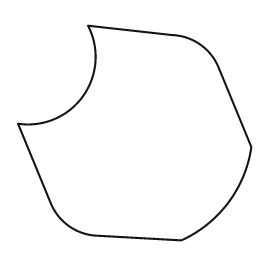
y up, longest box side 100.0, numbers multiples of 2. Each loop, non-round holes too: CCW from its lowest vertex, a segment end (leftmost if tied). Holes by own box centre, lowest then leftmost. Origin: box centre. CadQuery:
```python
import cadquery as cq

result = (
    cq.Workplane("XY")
    .moveTo(20.0, -46.0)
    .threePointArc((40.0, -30.0), (50.0, -6.0))
    .lineTo(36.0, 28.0)
    .threePointArc((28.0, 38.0), (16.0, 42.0))
    .lineTo(-20.0, 46.0)
    .threePointArc((-22.0, 16.0), (-50.0, 4.0))
    .lineTo(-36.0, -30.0)
    .threePointArc((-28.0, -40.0), (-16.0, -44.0))
    .close()
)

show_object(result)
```